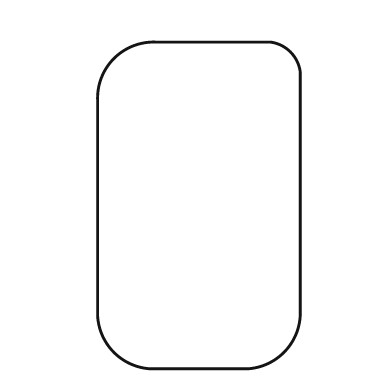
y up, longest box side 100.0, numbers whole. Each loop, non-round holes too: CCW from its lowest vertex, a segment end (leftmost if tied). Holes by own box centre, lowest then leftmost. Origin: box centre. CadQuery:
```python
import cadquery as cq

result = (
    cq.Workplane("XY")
    .moveTo(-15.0, -50.0)
    .lineTo(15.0, -50.0)
    .threePointArc((26.0, -45.0), (31.0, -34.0))
    .lineTo(31.0, 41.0)
    .threePointArc((28.0, 47.0), (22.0, 50.0))
    .lineTo(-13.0, 50.0)
    .threePointArc((-26.0, 45.0), (-31.0, 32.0))
    .lineTo(-31.0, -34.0)
    .threePointArc((-26.0, -45.0), (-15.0, -50.0))
    .close()
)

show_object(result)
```